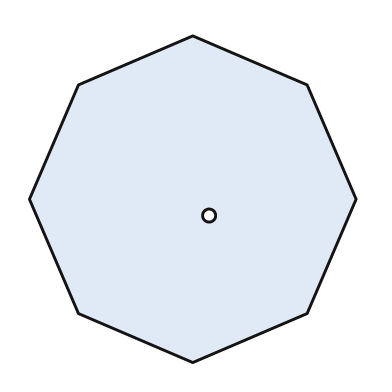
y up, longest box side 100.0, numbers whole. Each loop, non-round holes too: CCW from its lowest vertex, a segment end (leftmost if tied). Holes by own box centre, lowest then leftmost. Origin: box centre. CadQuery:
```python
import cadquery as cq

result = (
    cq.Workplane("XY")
    .moveTo(0.0, -50.0)
    .lineTo(35.0, -35.0)
    .lineTo(50.0, 0.0)
    .lineTo(35.0, 35.0)
    .lineTo(0.0, 50.0)
    .lineTo(-35.0, 35.0)
    .lineTo(-50.0, 0.0)
    .lineTo(-35.0, -35.0)
    .close()
    .moveTo(5.0, -5.0)
    .circle(2.0)
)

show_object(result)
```